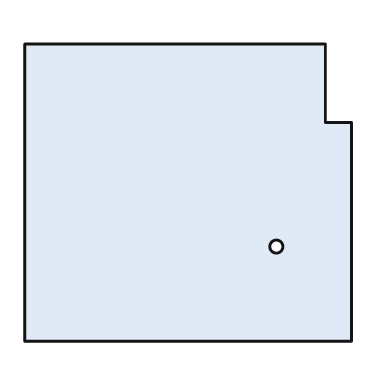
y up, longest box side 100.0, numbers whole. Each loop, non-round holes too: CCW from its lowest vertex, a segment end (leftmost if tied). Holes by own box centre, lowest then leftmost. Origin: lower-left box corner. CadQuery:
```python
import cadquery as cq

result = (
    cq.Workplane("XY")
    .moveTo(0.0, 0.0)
    .lineTo(100.0, 0.0)
    .lineTo(100.0, 67.0)
    .lineTo(92.0, 67.0)
    .lineTo(92.0, 91.0)
    .lineTo(0.0, 91.0)
    .close()
    .moveTo(77.0, 29.0)
    .circle(2.0)
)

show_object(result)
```